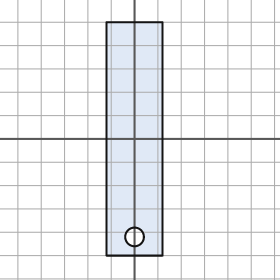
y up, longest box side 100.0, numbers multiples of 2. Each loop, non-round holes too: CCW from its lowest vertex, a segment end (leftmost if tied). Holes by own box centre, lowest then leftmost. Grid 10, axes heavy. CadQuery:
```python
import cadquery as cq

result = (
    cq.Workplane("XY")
    .moveTo(-12.0, -50.0)
    .lineTo(12.0, -50.0)
    .lineTo(12.0, 50.0)
    .lineTo(-12.0, 50.0)
    .close()
    .moveTo(0.0, -42.0)
    .circle(4.0)
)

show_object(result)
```